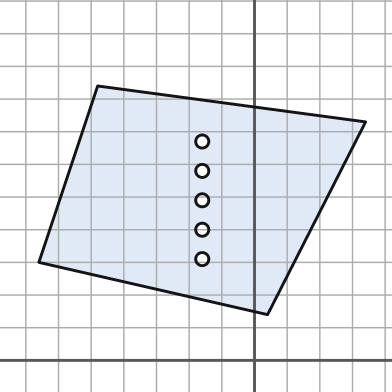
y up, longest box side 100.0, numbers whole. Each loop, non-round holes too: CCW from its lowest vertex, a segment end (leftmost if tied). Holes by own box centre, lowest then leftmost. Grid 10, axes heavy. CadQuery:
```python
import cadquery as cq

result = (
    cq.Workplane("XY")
    .moveTo(4.0, 14.0)
    .lineTo(34.0, 73.0)
    .lineTo(-48.0, 84.0)
    .lineTo(-66.0, 30.0)
    .close()
    .moveTo(-16.0, 31.0)
    .circle(2.0)
    .moveTo(-16.0, 40.0)
    .circle(2.0)
    .moveTo(-16.0, 49.0)
    .circle(2.0)
    .moveTo(-16.0, 58.0)
    .circle(2.0)
    .moveTo(-16.0, 67.0)
    .circle(2.0)
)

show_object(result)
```